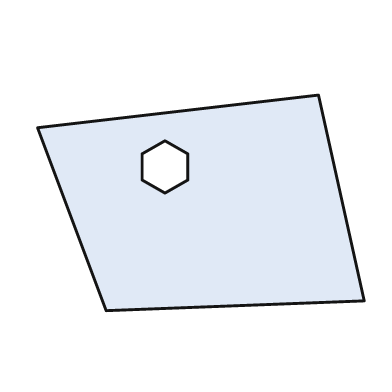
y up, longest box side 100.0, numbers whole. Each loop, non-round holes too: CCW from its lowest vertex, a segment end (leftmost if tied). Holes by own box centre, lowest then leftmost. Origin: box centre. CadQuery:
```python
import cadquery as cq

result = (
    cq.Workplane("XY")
    .moveTo(-29.0, -33.0)
    .lineTo(50.0, -30.0)
    .lineTo(36.0, 33.0)
    .lineTo(-50.0, 23.0)
    .close()
    .moveTo(-11.0, 3.0)
    .lineTo(-4.0, 7.0)
    .lineTo(-4.0, 15.0)
    .lineTo(-11.0, 19.0)
    .lineTo(-18.0, 15.0)
    .lineTo(-18.0, 7.0)
    .close()
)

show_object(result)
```